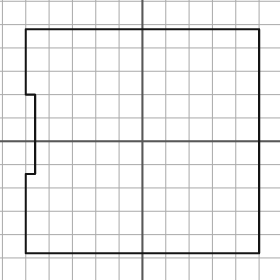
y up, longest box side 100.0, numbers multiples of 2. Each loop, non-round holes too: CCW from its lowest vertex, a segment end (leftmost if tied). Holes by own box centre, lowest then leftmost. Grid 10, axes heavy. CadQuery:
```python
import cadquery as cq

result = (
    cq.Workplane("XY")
    .moveTo(-50.0, -48.0)
    .lineTo(50.0, -48.0)
    .lineTo(50.0, 48.0)
    .lineTo(-50.0, 48.0)
    .lineTo(-50.0, 20.0)
    .lineTo(-46.0, 20.0)
    .lineTo(-46.0, -14.0)
    .lineTo(-50.0, -14.0)
    .close()
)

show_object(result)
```